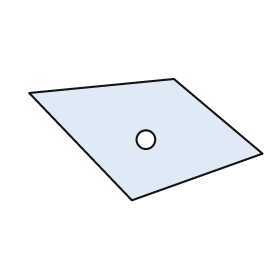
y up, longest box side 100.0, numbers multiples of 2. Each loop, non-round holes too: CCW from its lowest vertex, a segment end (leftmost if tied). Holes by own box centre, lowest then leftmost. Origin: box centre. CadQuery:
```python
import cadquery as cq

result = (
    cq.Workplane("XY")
    .moveTo(-6.0, -26.0)
    .lineTo(50.0, -6.0)
    .lineTo(12.0, 26.0)
    .lineTo(-50.0, 20.0)
    .close()
    .moveTo(0.0, 0.0)
    .circle(4.0)
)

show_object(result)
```